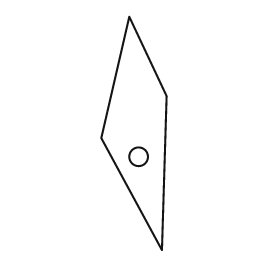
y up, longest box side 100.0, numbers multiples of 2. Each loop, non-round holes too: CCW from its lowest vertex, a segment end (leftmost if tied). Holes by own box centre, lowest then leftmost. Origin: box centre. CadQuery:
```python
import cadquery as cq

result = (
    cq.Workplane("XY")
    .moveTo(12.0, -50.0)
    .lineTo(14.0, 16.0)
    .lineTo(-2.0, 50.0)
    .lineTo(-14.0, -2.0)
    .close()
    .moveTo(2.0, -10.0)
    .circle(4.0)
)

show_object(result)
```